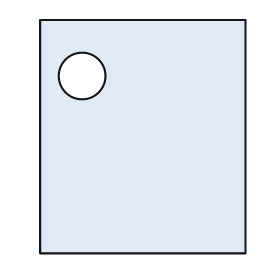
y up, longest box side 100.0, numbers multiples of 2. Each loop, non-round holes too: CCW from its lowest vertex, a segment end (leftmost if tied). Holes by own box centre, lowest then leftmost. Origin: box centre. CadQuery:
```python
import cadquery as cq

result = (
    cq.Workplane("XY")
    .moveTo(-44.0, -50.0)
    .lineTo(44.0, -50.0)
    .lineTo(44.0, 50.0)
    .lineTo(-44.0, 50.0)
    .close()
    .moveTo(-26.0, 26.0)
    .circle(10.0)
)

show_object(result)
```